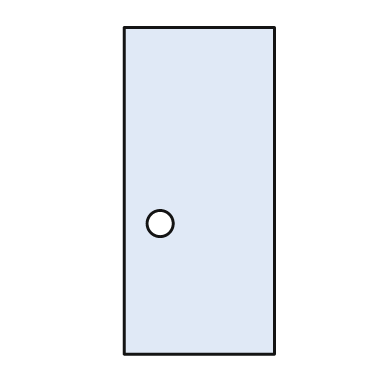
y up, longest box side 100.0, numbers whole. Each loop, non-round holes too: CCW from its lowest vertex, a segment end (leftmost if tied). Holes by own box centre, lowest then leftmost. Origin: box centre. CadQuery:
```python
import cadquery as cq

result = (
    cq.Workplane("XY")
    .moveTo(-23.0, -50.0)
    .lineTo(23.0, -50.0)
    .lineTo(23.0, 50.0)
    .lineTo(-23.0, 50.0)
    .close()
    .moveTo(-12.0, -10.0)
    .circle(4.0)
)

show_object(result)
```